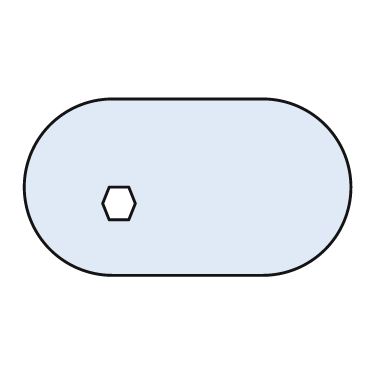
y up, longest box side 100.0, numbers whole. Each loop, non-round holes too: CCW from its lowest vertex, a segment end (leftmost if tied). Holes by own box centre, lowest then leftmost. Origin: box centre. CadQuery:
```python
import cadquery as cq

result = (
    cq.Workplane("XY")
    .moveTo(-23.0, -27.0)
    .lineTo(23.0, -27.0)
    .threePointArc((50.0, 0.0), (23.0, 27.0))
    .lineTo(-23.0, 27.0)
    .threePointArc((-50.0, 0.0), (-23.0, -27.0))
    .close()
    .moveTo(-24.0, -10.0)
    .lineTo(-18.0, -10.0)
    .lineTo(-16.0, -5.0)
    .lineTo(-18.0, 0.0)
    .lineTo(-24.0, 0.0)
    .lineTo(-26.0, -5.0)
    .close()
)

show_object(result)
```